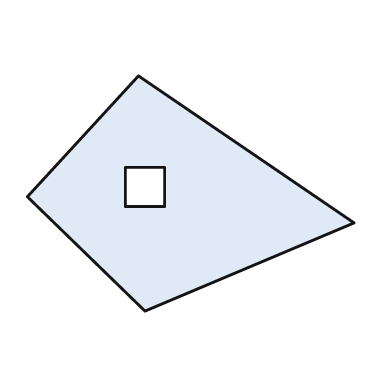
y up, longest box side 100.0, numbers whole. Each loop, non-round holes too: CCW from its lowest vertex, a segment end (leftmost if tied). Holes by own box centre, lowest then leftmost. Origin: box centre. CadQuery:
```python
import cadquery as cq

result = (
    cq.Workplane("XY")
    .moveTo(-14.0, -36.0)
    .lineTo(50.0, -9.0)
    .lineTo(-16.0, 36.0)
    .lineTo(-50.0, -1.0)
    .close()
    .moveTo(-20.0, -4.0)
    .lineTo(-8.0, -4.0)
    .lineTo(-8.0, 8.0)
    .lineTo(-20.0, 8.0)
    .close()
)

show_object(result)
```